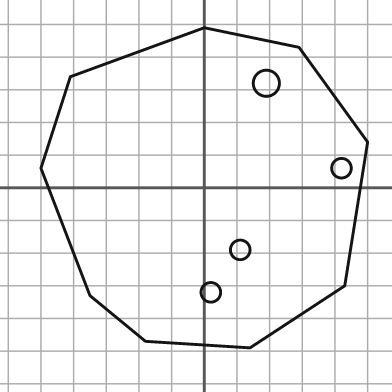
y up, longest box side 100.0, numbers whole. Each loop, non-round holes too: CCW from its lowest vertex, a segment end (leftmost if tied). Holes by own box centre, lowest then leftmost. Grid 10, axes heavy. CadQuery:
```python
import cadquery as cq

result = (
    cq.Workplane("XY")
    .moveTo(14.0, -49.0)
    .lineTo(43.0, -30.0)
    .lineTo(50.0, 14.0)
    .lineTo(29.0, 43.0)
    .lineTo(0.0, 49.0)
    .lineTo(-41.0, 34.0)
    .lineTo(-50.0, 6.0)
    .lineTo(-35.0, -33.0)
    .lineTo(-18.0, -47.0)
    .close()
    .moveTo(2.0, -32.0)
    .circle(3.0)
    .moveTo(11.0, -19.0)
    .circle(3.0)
    .moveTo(42.0, 6.0)
    .circle(3.0)
    .moveTo(19.0, 32.0)
    .circle(4.0)
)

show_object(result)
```